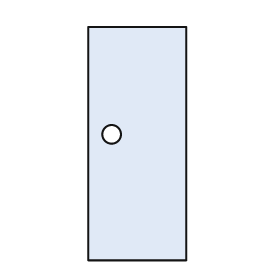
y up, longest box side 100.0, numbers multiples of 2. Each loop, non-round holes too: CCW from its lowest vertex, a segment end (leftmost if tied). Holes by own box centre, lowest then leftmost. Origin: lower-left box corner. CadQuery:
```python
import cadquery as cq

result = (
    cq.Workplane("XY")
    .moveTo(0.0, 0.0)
    .lineTo(42.0, 0.0)
    .lineTo(42.0, 100.0)
    .lineTo(0.0, 100.0)
    .close()
    .moveTo(10.0, 54.0)
    .circle(4.0)
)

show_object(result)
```